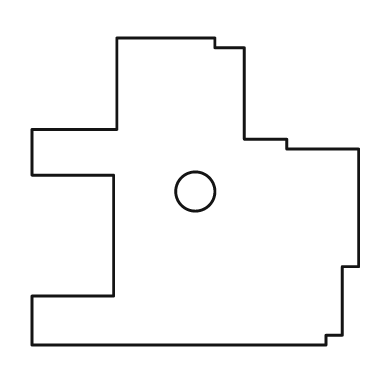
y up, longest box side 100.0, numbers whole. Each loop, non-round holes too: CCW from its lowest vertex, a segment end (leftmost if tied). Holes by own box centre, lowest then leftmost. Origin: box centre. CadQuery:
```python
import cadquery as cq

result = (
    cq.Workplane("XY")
    .moveTo(-50.0, -47.0)
    .lineTo(40.0, -47.0)
    .lineTo(40.0, -44.0)
    .lineTo(45.0, -44.0)
    .lineTo(45.0, -23.0)
    .lineTo(50.0, -23.0)
    .lineTo(50.0, 13.0)
    .lineTo(28.0, 13.0)
    .lineTo(28.0, 16.0)
    .lineTo(15.0, 16.0)
    .lineTo(15.0, 44.0)
    .lineTo(6.0, 44.0)
    .lineTo(6.0, 47.0)
    .lineTo(-24.0, 47.0)
    .lineTo(-24.0, 19.0)
    .lineTo(-50.0, 19.0)
    .lineTo(-50.0, 5.0)
    .lineTo(-25.0, 5.0)
    .lineTo(-25.0, -32.0)
    .lineTo(-50.0, -32.0)
    .close()
    .moveTo(0.0, 0.0)
    .circle(6.0)
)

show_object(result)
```